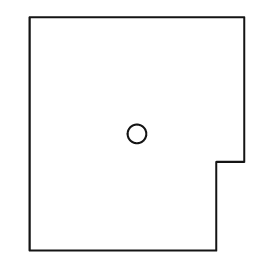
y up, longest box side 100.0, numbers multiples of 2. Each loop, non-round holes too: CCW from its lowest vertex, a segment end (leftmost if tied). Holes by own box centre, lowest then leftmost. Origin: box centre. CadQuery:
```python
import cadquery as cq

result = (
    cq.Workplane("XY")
    .moveTo(-46.0, -50.0)
    .lineTo(34.0, -50.0)
    .lineTo(34.0, -12.0)
    .lineTo(46.0, -12.0)
    .lineTo(46.0, 50.0)
    .lineTo(-46.0, 50.0)
    .close()
    .moveTo(0.0, 0.0)
    .circle(4.0)
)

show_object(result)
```